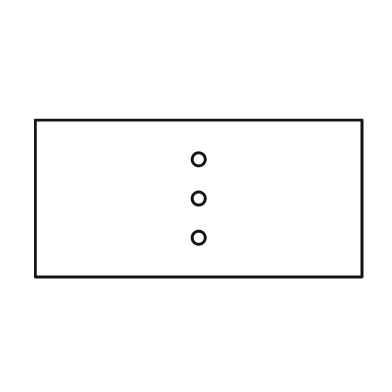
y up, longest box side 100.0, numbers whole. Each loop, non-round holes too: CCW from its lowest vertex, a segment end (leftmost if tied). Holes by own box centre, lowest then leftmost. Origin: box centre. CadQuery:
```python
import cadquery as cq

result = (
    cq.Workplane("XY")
    .moveTo(-50.0, -24.0)
    .lineTo(50.0, -24.0)
    .lineTo(50.0, 24.0)
    .lineTo(-50.0, 24.0)
    .close()
    .moveTo(0.0, -12.0)
    .circle(2.0)
    .moveTo(0.0, 0.0)
    .circle(2.0)
    .moveTo(0.0, 12.0)
    .circle(2.0)
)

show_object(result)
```